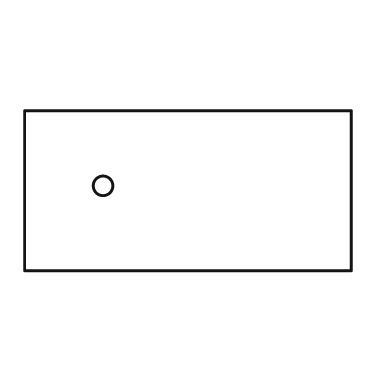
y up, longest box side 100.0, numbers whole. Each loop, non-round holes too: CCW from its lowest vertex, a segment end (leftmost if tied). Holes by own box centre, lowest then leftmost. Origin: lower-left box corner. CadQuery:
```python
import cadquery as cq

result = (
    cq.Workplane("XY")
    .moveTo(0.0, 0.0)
    .lineTo(100.0, 0.0)
    .lineTo(100.0, 49.0)
    .lineTo(0.0, 49.0)
    .close()
    .moveTo(24.0, 26.0)
    .circle(3.0)
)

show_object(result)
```